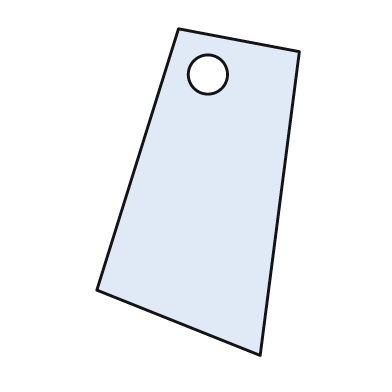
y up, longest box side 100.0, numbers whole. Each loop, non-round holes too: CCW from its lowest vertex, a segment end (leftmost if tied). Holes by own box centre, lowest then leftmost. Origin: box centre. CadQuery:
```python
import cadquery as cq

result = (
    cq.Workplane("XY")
    .moveTo(19.0, -50.0)
    .lineTo(31.0, 43.0)
    .lineTo(-6.0, 50.0)
    .lineTo(-31.0, -30.0)
    .close()
    .moveTo(3.0, 36.0)
    .circle(6.0)
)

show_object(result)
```